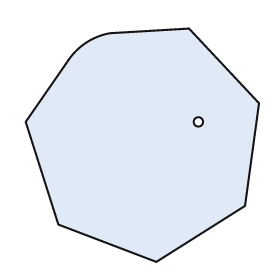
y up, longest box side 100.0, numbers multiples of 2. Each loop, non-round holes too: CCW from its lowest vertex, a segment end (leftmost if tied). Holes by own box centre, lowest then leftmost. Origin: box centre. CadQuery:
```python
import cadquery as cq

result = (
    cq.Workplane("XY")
    .moveTo(6.0, -50.0)
    .lineTo(44.0, -26.0)
    .lineTo(50.0, 18.0)
    .lineTo(20.0, 50.0)
    .lineTo(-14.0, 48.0)
    .threePointArc((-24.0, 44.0), (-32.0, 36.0))
    .lineTo(-50.0, 10.0)
    .lineTo(-36.0, -34.0)
    .close()
    .moveTo(24.0, 10.0)
    .circle(2.0)
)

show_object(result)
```